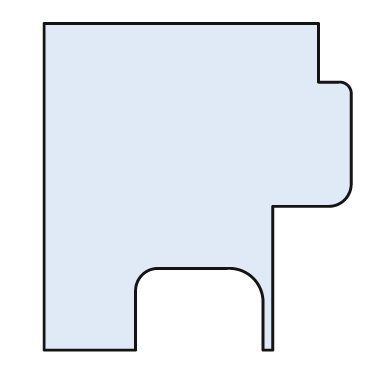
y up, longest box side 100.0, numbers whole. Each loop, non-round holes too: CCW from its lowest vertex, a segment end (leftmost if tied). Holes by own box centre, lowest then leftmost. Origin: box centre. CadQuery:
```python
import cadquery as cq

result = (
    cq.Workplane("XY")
    .moveTo(-47.0, -50.0)
    .lineTo(-19.0, -50.0)
    .lineTo(-19.0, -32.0)
    .threePointArc((-17.0, -27.0), (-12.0, -25.0))
    .lineTo(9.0, -25.0)
    .threePointArc((17.0, -28.0), (20.0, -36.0))
    .lineTo(20.0, -50.0)
    .lineTo(23.0, -50.0)
    .lineTo(23.0, -6.0)
    .lineTo(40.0, -6.0)
    .threePointArc((45.0, -4.0), (47.0, 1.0))
    .lineTo(47.0, 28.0)
    .threePointArc((46.0, 31.0), (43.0, 32.0))
    .lineTo(37.0, 32.0)
    .lineTo(37.0, 50.0)
    .lineTo(-47.0, 50.0)
    .close()
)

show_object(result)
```